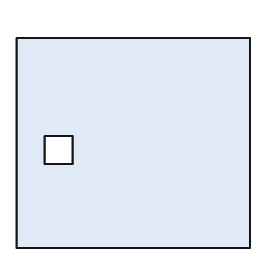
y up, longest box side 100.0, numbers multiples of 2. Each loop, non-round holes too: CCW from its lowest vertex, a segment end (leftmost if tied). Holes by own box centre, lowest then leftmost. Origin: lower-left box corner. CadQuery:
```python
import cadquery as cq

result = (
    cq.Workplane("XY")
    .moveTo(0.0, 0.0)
    .lineTo(100.0, 0.0)
    .lineTo(100.0, 90.0)
    .lineTo(0.0, 90.0)
    .close()
    .moveTo(12.0, 36.0)
    .lineTo(24.0, 36.0)
    .lineTo(24.0, 48.0)
    .lineTo(12.0, 48.0)
    .close()
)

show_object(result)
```